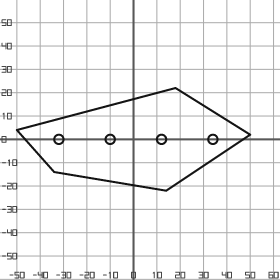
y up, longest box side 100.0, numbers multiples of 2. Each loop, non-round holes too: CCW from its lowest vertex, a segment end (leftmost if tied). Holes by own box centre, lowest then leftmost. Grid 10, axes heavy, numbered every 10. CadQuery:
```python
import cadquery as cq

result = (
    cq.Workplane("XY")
    .moveTo(14.0, -22.0)
    .lineTo(50.0, 2.0)
    .lineTo(18.0, 22.0)
    .lineTo(-50.0, 4.0)
    .lineTo(-34.0, -14.0)
    .close()
    .moveTo(-32.0, 0.0)
    .circle(2.0)
    .moveTo(-10.0, 0.0)
    .circle(2.0)
    .moveTo(12.0, 0.0)
    .circle(2.0)
    .moveTo(34.0, 0.0)
    .circle(2.0)
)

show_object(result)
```